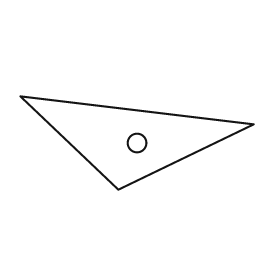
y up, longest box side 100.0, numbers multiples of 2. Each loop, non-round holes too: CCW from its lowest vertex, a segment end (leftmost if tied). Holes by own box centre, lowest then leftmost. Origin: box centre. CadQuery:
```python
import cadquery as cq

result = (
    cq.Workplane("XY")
    .moveTo(-8.0, -20.0)
    .lineTo(50.0, 8.0)
    .lineTo(-50.0, 20.0)
    .close()
    .moveTo(0.0, 0.0)
    .circle(4.0)
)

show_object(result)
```